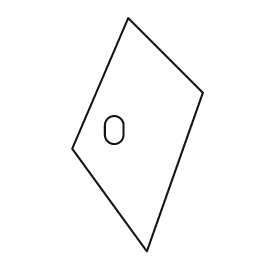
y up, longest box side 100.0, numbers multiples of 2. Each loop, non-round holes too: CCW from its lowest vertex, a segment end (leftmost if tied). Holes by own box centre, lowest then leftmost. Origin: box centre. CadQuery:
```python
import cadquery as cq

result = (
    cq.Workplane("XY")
    .moveTo(4.0, -50.0)
    .lineTo(28.0, 18.0)
    .lineTo(-4.0, 50.0)
    .lineTo(-28.0, -6.0)
    .close()
    .moveTo(-14.0, 0.0)
    .threePointArc((-10.0, -4.0), (-6.0, 0.0))
    .lineTo(-6.0, 4.0)
    .threePointArc((-10.0, 8.0), (-14.0, 4.0))
    .close()
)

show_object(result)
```